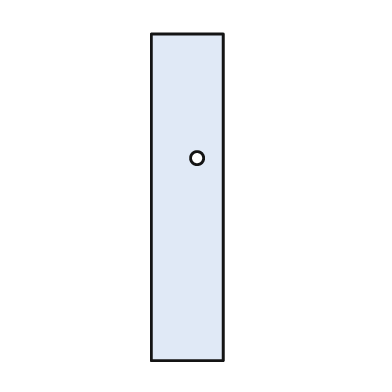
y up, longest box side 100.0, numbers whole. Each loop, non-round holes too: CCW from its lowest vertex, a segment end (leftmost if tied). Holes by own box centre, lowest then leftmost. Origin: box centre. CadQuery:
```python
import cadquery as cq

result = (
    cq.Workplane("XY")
    .moveTo(-11.0, -50.0)
    .lineTo(11.0, -50.0)
    .lineTo(11.0, 50.0)
    .lineTo(-11.0, 50.0)
    .close()
    .moveTo(3.0, 12.0)
    .circle(2.0)
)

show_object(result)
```